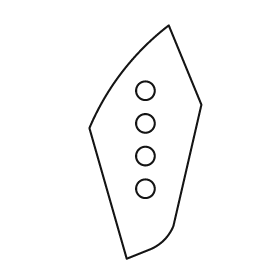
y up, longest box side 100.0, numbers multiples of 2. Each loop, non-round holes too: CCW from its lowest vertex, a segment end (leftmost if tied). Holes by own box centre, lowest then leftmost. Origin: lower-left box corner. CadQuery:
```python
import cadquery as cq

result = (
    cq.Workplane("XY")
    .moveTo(16.0, 0.0)
    .lineTo(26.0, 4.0)
    .threePointArc((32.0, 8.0), (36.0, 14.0))
    .lineTo(48.0, 66.0)
    .lineTo(34.0, 100.0)
    .threePointArc((14.0, 80.0), (0.0, 56.0))
    .close()
    .moveTo(24.0, 30.0)
    .circle(4.0)
    .moveTo(24.0, 44.0)
    .circle(4.0)
    .moveTo(24.0, 58.0)
    .circle(4.0)
    .moveTo(24.0, 72.0)
    .circle(4.0)
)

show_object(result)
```